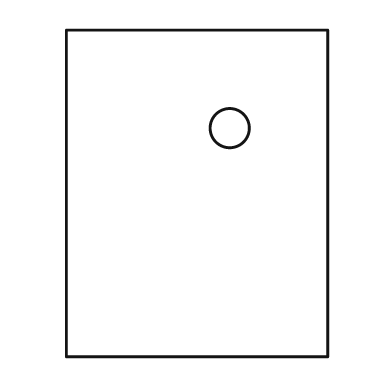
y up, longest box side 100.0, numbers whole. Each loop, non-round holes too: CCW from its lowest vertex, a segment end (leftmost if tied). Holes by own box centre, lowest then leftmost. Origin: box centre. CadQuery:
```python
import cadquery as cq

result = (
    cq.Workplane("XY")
    .moveTo(-40.0, -50.0)
    .lineTo(40.0, -50.0)
    .lineTo(40.0, 50.0)
    .lineTo(-40.0, 50.0)
    .close()
    .moveTo(10.0, 20.0)
    .circle(6.0)
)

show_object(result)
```